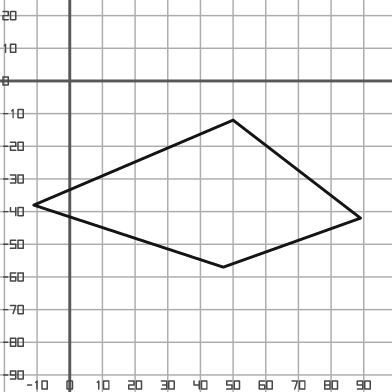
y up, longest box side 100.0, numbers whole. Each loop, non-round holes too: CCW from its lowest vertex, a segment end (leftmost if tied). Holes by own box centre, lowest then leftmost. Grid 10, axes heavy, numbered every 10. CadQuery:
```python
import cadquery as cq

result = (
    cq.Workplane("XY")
    .moveTo(47.0, -57.0)
    .lineTo(89.0, -42.0)
    .lineTo(50.0, -12.0)
    .lineTo(-11.0, -38.0)
    .close()
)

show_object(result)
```